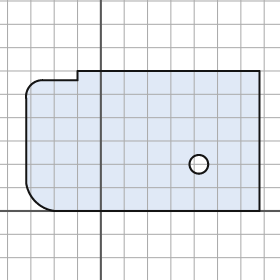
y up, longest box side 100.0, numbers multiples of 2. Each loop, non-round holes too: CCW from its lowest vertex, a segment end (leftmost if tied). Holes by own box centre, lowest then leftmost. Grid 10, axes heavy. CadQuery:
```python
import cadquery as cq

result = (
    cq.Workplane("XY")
    .moveTo(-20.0, 0.0)
    .lineTo(68.0, 0.0)
    .lineTo(68.0, 60.0)
    .lineTo(-10.0, 60.0)
    .lineTo(-10.0, 56.0)
    .lineTo(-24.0, 56.0)
    .threePointArc((-30.0, 54.0), (-32.0, 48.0))
    .lineTo(-32.0, 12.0)
    .threePointArc((-28.0, 4.0), (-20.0, 0.0))
    .close()
    .moveTo(42.0, 20.0)
    .circle(4.0)
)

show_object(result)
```